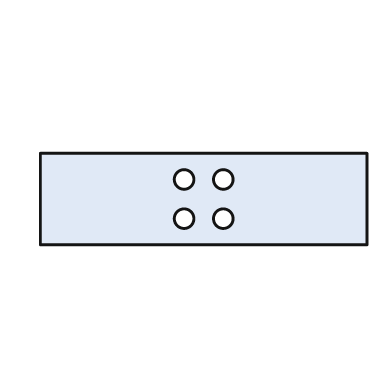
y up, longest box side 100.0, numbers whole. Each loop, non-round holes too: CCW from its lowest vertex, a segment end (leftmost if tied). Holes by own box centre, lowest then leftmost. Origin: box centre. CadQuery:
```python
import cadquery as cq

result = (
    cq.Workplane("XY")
    .moveTo(-50.0, -14.0)
    .lineTo(50.0, -14.0)
    .lineTo(50.0, 14.0)
    .lineTo(-50.0, 14.0)
    .close()
    .moveTo(-6.0, -6.0)
    .circle(3.0)
    .moveTo(6.0, -6.0)
    .circle(3.0)
    .moveTo(-6.0, 6.0)
    .circle(3.0)
    .moveTo(6.0, 6.0)
    .circle(3.0)
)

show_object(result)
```